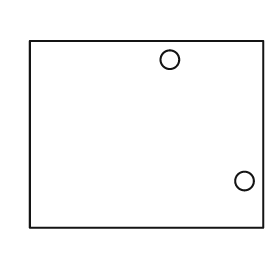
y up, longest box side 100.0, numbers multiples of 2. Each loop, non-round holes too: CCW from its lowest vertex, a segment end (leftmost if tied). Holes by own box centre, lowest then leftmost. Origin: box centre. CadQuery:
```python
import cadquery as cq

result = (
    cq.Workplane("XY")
    .moveTo(-50.0, -40.0)
    .lineTo(50.0, -40.0)
    .lineTo(50.0, 40.0)
    .lineTo(-50.0, 40.0)
    .close()
    .moveTo(42.0, -20.0)
    .circle(4.0)
    .moveTo(10.0, 32.0)
    .circle(4.0)
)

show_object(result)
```